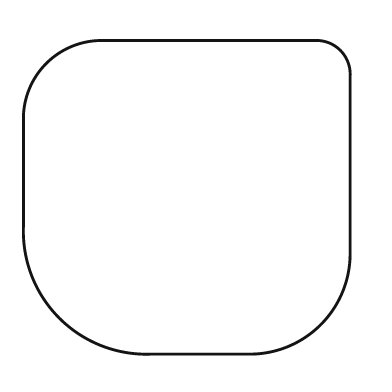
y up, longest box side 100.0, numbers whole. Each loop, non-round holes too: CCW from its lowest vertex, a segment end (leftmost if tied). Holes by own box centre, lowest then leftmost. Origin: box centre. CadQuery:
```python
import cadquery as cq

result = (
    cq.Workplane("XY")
    .moveTo(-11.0, -48.0)
    .lineTo(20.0, -48.0)
    .threePointArc((41.0, -39.0), (50.0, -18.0))
    .lineTo(50.0, 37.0)
    .threePointArc((47.0, 45.0), (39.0, 48.0))
    .lineTo(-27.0, 48.0)
    .threePointArc((-43.0, 41.0), (-50.0, 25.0))
    .lineTo(-50.0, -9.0)
    .threePointArc((-39.0, -37.0), (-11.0, -48.0))
    .close()
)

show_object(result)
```